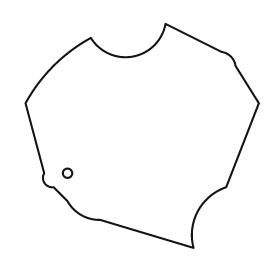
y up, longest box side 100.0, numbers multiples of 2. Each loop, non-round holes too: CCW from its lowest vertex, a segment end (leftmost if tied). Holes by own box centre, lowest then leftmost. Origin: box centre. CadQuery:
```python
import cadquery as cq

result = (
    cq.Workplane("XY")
    .moveTo(22.0, -48.0)
    .threePointArc((24.0, -32.0), (36.0, -22.0))
    .lineTo(50.0, 14.0)
    .lineTo(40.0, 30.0)
    .threePointArc((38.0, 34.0), (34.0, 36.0))
    .lineTo(10.0, 48.0)
    .threePointArc((-4.0, 34.0), (-22.0, 42.0))
    .threePointArc((-38.0, 30.0), (-50.0, 14.0))
    .lineTo(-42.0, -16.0)
    .threePointArc((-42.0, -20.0), (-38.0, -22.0))
    .lineTo(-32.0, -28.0)
    .threePointArc((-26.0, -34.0), (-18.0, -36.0))
    .close()
    .moveTo(-32.0, -16.0)
    .circle(2.0)
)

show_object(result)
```